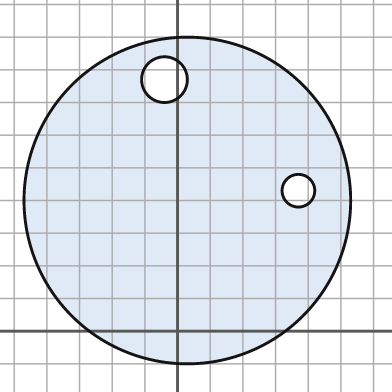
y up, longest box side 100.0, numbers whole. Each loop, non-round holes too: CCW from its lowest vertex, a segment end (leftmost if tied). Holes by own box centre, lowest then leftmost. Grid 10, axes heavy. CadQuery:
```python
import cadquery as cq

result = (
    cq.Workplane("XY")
    .moveTo(3.0, 40.0)
    .circle(50.0)
    .moveTo(37.0, 43.0)
    .circle(5.0)
    .moveTo(-4.0, 77.0)
    .circle(7.0)
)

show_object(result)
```